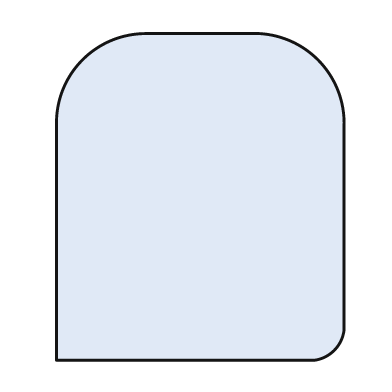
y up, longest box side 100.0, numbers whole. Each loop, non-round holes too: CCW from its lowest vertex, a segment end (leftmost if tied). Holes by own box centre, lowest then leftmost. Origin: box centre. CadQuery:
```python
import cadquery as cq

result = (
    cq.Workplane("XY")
    .moveTo(-44.0, -50.0)
    .lineTo(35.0, -50.0)
    .threePointArc((41.0, -47.0), (44.0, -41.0))
    .lineTo(44.0, 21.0)
    .threePointArc((36.0, 42.0), (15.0, 50.0))
    .lineTo(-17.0, 50.0)
    .threePointArc((-36.0, 42.0), (-44.0, 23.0))
    .close()
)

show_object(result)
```